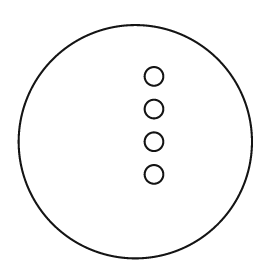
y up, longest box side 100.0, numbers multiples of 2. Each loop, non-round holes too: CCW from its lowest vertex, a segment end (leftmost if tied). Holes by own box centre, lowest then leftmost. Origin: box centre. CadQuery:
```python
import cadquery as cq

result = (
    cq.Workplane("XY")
    .moveTo(0.0, 0.0)
    .circle(50.0)
    .moveTo(8.0, -14.0)
    .circle(4.0)
    .moveTo(8.0, 0.0)
    .circle(4.0)
    .moveTo(8.0, 14.0)
    .circle(4.0)
    .moveTo(8.0, 28.0)
    .circle(4.0)
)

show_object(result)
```